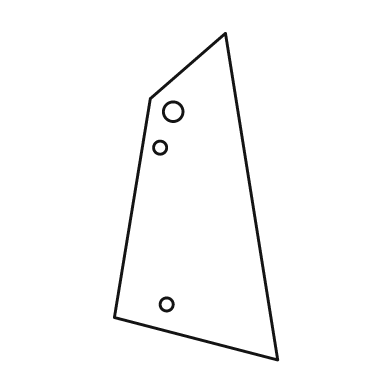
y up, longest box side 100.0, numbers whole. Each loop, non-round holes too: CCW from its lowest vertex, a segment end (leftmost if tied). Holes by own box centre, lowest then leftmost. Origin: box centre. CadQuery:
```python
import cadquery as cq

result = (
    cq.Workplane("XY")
    .moveTo(25.0, -50.0)
    .lineTo(9.0, 50.0)
    .lineTo(-14.0, 30.0)
    .lineTo(-25.0, -37.0)
    .close()
    .moveTo(-9.0, -33.0)
    .circle(2.0)
    .moveTo(-11.0, 15.0)
    .circle(2.0)
    .moveTo(-7.0, 26.0)
    .circle(3.0)
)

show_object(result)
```